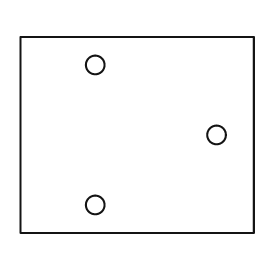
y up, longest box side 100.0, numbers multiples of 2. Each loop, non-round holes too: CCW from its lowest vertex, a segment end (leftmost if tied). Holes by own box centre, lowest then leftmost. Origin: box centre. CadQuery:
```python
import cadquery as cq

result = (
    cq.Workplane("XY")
    .moveTo(-50.0, -42.0)
    .lineTo(50.0, -42.0)
    .lineTo(50.0, 42.0)
    .lineTo(-50.0, 42.0)
    .close()
    .moveTo(-18.0, -30.0)
    .circle(4.0)
    .moveTo(34.0, 0.0)
    .circle(4.0)
    .moveTo(-18.0, 30.0)
    .circle(4.0)
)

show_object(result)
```